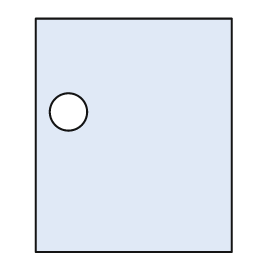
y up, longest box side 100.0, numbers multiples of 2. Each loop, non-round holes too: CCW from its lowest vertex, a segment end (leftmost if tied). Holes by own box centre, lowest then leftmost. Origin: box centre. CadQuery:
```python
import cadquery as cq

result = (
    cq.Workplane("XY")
    .moveTo(-42.0, -50.0)
    .lineTo(42.0, -50.0)
    .lineTo(42.0, 50.0)
    .lineTo(-42.0, 50.0)
    .close()
    .moveTo(-28.0, 10.0)
    .circle(8.0)
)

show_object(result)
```